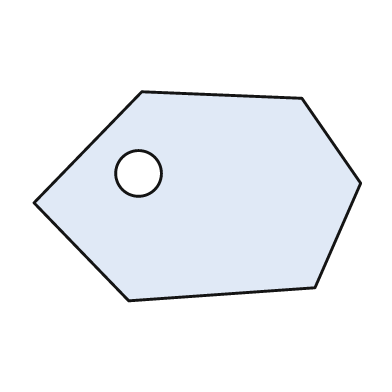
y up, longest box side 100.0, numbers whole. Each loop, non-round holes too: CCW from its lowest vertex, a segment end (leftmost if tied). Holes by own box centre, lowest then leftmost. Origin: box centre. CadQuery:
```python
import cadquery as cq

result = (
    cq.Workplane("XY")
    .moveTo(-21.0, -32.0)
    .lineTo(36.0, -28.0)
    .lineTo(50.0, 4.0)
    .lineTo(32.0, 30.0)
    .lineTo(-17.0, 32.0)
    .lineTo(-50.0, -2.0)
    .close()
    .moveTo(-18.0, 7.0)
    .circle(7.0)
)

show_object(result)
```